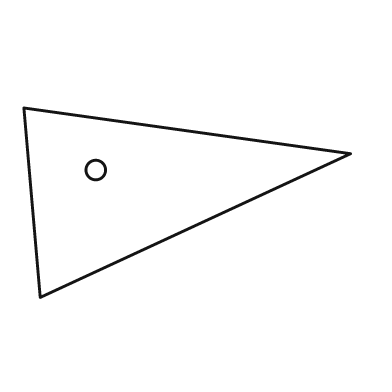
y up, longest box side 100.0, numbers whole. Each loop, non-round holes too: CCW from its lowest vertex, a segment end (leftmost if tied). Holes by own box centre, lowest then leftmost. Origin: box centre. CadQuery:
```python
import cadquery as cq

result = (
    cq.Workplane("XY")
    .moveTo(-45.0, -29.0)
    .lineTo(50.0, 15.0)
    .lineTo(-50.0, 29.0)
    .close()
    .moveTo(-28.0, 10.0)
    .circle(3.0)
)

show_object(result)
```